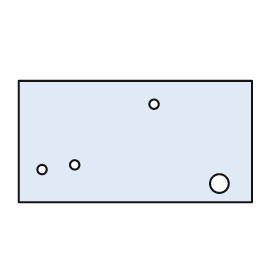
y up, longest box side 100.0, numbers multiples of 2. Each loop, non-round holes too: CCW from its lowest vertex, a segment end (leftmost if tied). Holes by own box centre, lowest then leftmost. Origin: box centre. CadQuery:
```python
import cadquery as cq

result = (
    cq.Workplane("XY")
    .moveTo(-50.0, -26.0)
    .lineTo(50.0, -26.0)
    .lineTo(50.0, 26.0)
    .lineTo(-50.0, 26.0)
    .close()
    .moveTo(36.0, -18.0)
    .circle(4.0)
    .moveTo(-40.0, -12.0)
    .circle(2.0)
    .moveTo(-26.0, -10.0)
    .circle(2.0)
    .moveTo(8.0, 16.0)
    .circle(2.0)
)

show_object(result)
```